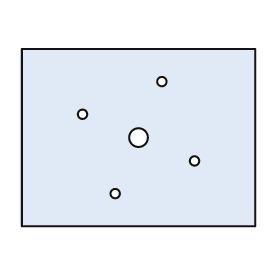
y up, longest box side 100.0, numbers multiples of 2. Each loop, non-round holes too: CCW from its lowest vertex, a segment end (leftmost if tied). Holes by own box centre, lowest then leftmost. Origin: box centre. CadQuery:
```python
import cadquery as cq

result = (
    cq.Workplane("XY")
    .moveTo(-50.0, -38.0)
    .lineTo(50.0, -38.0)
    .lineTo(50.0, 38.0)
    .lineTo(-50.0, 38.0)
    .close()
    .moveTo(-10.0, -24.0)
    .circle(2.0)
    .moveTo(24.0, -10.0)
    .circle(2.0)
    .moveTo(0.0, 0.0)
    .circle(4.0)
    .moveTo(-24.0, 10.0)
    .circle(2.0)
    .moveTo(10.0, 24.0)
    .circle(2.0)
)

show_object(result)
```